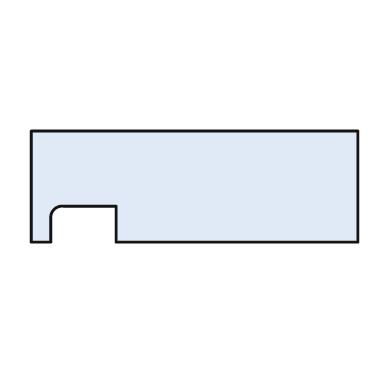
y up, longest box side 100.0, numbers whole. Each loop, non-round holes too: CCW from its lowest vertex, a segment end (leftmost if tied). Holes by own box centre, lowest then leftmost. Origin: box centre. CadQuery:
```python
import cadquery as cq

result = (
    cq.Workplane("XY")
    .moveTo(-50.0, -17.0)
    .lineTo(-44.0, -17.0)
    .lineTo(-44.0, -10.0)
    .threePointArc((-43.0, -7.0), (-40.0, -6.0))
    .lineTo(-24.0, -6.0)
    .lineTo(-24.0, -17.0)
    .lineTo(50.0, -17.0)
    .lineTo(50.0, 17.0)
    .lineTo(-50.0, 17.0)
    .close()
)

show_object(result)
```